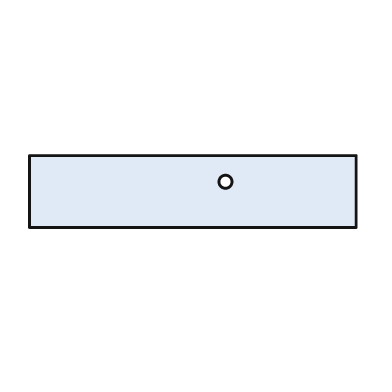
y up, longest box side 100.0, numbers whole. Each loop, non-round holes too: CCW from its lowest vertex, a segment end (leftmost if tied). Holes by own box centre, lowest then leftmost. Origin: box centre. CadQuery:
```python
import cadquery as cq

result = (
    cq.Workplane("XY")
    .moveTo(-50.0, -11.0)
    .lineTo(50.0, -11.0)
    .lineTo(50.0, 11.0)
    .lineTo(-50.0, 11.0)
    .close()
    .moveTo(10.0, 3.0)
    .circle(2.0)
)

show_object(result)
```